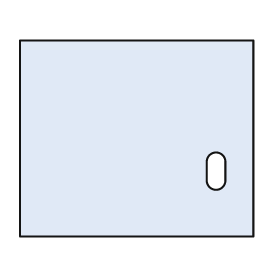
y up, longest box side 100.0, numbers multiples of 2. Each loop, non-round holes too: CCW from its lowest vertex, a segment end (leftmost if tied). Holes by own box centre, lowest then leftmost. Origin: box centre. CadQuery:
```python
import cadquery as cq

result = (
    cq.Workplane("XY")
    .moveTo(-50.0, -42.0)
    .lineTo(50.0, -42.0)
    .lineTo(50.0, 42.0)
    .lineTo(-50.0, 42.0)
    .close()
    .moveTo(30.0, -18.0)
    .threePointArc((34.0, -22.0), (38.0, -18.0))
    .lineTo(38.0, -10.0)
    .threePointArc((34.0, -6.0), (30.0, -10.0))
    .close()
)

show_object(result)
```